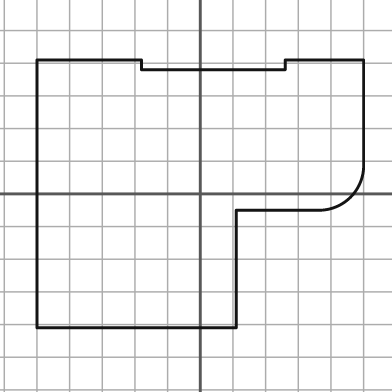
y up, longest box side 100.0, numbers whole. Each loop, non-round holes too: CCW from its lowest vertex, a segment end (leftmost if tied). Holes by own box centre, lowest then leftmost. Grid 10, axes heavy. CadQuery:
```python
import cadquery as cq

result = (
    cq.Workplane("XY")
    .moveTo(-50.0, -41.0)
    .lineTo(11.0, -41.0)
    .lineTo(11.0, -5.0)
    .lineTo(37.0, -5.0)
    .threePointArc((46.0, -1.0), (50.0, 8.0))
    .lineTo(50.0, 41.0)
    .lineTo(26.0, 41.0)
    .lineTo(26.0, 38.0)
    .lineTo(-18.0, 38.0)
    .lineTo(-18.0, 41.0)
    .lineTo(-50.0, 41.0)
    .close()
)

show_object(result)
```